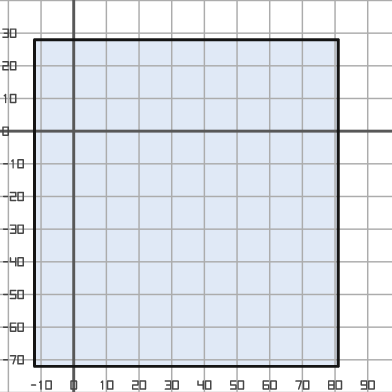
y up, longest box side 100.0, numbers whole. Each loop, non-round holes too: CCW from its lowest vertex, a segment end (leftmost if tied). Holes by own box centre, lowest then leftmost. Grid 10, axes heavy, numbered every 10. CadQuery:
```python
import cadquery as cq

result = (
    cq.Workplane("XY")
    .moveTo(-12.0, -72.0)
    .lineTo(81.0, -72.0)
    .lineTo(81.0, 28.0)
    .lineTo(-12.0, 28.0)
    .close()
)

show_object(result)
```